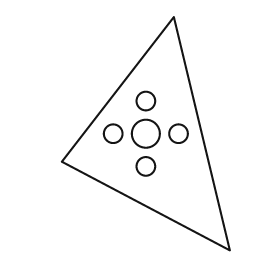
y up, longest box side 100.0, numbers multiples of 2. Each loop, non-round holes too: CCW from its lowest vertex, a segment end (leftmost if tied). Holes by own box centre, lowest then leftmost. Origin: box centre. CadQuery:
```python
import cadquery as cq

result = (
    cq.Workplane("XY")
    .moveTo(36.0, -50.0)
    .lineTo(12.0, 50.0)
    .lineTo(-36.0, -12.0)
    .close()
    .moveTo(0.0, -14.0)
    .circle(4.0)
    .moveTo(-14.0, 0.0)
    .circle(4.0)
    .moveTo(0.0, 0.0)
    .circle(6.0)
    .moveTo(14.0, 0.0)
    .circle(4.0)
    .moveTo(0.0, 14.0)
    .circle(4.0)
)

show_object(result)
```